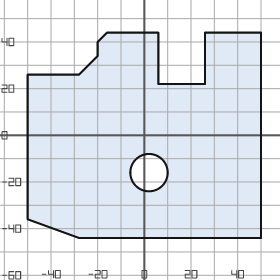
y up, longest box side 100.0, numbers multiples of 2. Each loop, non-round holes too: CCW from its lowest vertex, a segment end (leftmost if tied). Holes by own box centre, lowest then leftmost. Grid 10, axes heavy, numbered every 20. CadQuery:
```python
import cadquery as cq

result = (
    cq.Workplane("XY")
    .moveTo(-28.0, -44.0)
    .lineTo(50.0, -44.0)
    .lineTo(50.0, 44.0)
    .lineTo(26.0, 44.0)
    .lineTo(26.0, 22.0)
    .lineTo(6.0, 22.0)
    .lineTo(6.0, 44.0)
    .lineTo(-16.0, 44.0)
    .lineTo(-20.0, 40.0)
    .lineTo(-20.0, 34.0)
    .lineTo(-28.0, 26.0)
    .lineTo(-50.0, 26.0)
    .lineTo(-50.0, -36.0)
    .close()
    .moveTo(2.0, -16.0)
    .circle(8.0)
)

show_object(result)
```